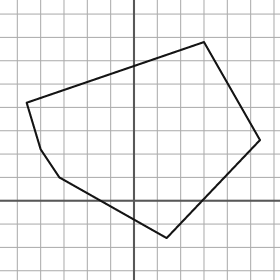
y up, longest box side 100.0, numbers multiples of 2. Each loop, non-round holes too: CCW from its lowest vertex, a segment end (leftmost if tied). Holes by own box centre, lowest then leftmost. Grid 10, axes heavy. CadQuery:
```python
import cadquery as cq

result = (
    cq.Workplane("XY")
    .moveTo(14.0, -16.0)
    .lineTo(54.0, 26.0)
    .lineTo(30.0, 68.0)
    .lineTo(-46.0, 42.0)
    .lineTo(-40.0, 22.0)
    .lineTo(-32.0, 10.0)
    .close()
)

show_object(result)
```